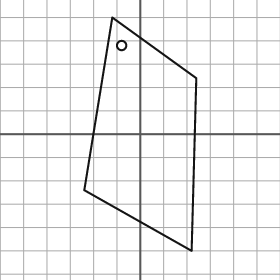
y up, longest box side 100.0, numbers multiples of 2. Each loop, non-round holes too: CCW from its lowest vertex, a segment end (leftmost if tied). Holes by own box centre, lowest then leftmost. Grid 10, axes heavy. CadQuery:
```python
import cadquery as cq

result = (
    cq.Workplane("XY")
    .moveTo(22.0, -50.0)
    .lineTo(24.0, 24.0)
    .lineTo(-12.0, 50.0)
    .lineTo(-24.0, -24.0)
    .close()
    .moveTo(-8.0, 38.0)
    .circle(2.0)
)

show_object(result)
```